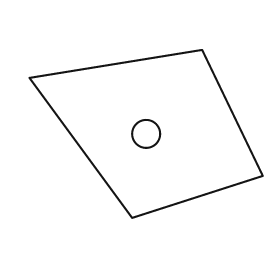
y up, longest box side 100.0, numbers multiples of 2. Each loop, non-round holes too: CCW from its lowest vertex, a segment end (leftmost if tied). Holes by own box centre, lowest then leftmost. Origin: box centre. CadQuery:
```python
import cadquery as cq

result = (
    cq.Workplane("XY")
    .moveTo(-6.0, -36.0)
    .lineTo(50.0, -18.0)
    .lineTo(24.0, 36.0)
    .lineTo(-50.0, 24.0)
    .close()
    .moveTo(0.0, 0.0)
    .circle(6.0)
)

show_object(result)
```